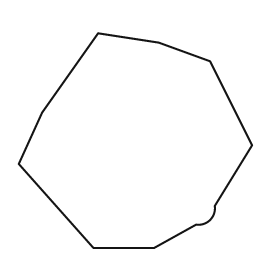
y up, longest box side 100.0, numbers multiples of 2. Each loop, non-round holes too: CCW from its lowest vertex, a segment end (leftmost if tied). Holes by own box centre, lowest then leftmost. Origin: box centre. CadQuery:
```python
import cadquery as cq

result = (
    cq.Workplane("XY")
    .moveTo(-18.0, -46.0)
    .lineTo(8.0, -46.0)
    .lineTo(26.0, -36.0)
    .threePointArc((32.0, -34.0), (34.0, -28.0))
    .lineTo(50.0, -2.0)
    .lineTo(32.0, 34.0)
    .lineTo(10.0, 42.0)
    .lineTo(-16.0, 46.0)
    .lineTo(-40.0, 12.0)
    .lineTo(-50.0, -10.0)
    .close()
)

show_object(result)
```